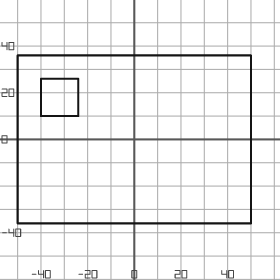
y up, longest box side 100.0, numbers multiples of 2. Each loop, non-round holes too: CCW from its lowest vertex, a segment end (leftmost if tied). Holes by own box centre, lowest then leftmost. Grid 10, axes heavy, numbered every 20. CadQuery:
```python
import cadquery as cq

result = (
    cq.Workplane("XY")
    .moveTo(-50.0, -36.0)
    .lineTo(50.0, -36.0)
    .lineTo(50.0, 36.0)
    .lineTo(-50.0, 36.0)
    .close()
    .moveTo(-40.0, 10.0)
    .lineTo(-24.0, 10.0)
    .lineTo(-24.0, 26.0)
    .lineTo(-40.0, 26.0)
    .close()
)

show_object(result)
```